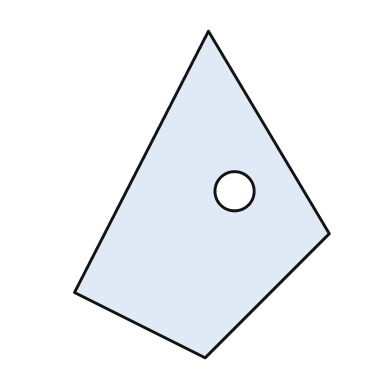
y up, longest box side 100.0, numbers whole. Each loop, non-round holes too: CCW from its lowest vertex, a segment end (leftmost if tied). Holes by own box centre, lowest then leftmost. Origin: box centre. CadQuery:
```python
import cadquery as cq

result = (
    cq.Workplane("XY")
    .moveTo(1.0, -50.0)
    .lineTo(39.0, -12.0)
    .lineTo(2.0, 50.0)
    .lineTo(-39.0, -30.0)
    .close()
    .moveTo(10.0, 1.0)
    .circle(6.0)
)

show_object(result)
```